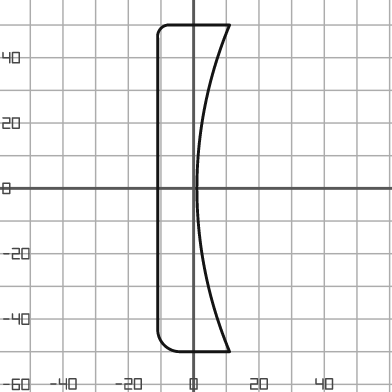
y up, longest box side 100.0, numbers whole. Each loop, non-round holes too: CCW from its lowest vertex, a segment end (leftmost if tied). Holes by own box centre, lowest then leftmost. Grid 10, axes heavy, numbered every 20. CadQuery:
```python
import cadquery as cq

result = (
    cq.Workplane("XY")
    .moveTo(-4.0, -50.0)
    .lineTo(11.0, -50.0)
    .threePointArc((1.0, 0.0), (11.0, 50.0))
    .lineTo(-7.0, 50.0)
    .threePointArc((-10.0, 49.0), (-11.0, 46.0))
    .lineTo(-11.0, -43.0)
    .threePointArc((-9.0, -48.0), (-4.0, -50.0))
    .close()
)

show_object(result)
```